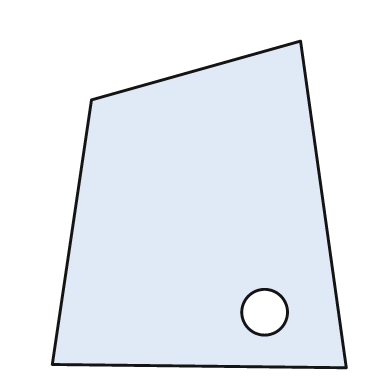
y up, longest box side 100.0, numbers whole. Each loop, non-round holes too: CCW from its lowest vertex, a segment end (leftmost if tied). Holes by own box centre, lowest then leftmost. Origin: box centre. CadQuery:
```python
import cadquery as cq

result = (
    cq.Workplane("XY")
    .moveTo(45.0, -50.0)
    .lineTo(31.0, 50.0)
    .lineTo(-33.0, 32.0)
    .lineTo(-45.0, -49.0)
    .close()
    .moveTo(20.0, -33.0)
    .circle(7.0)
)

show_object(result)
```